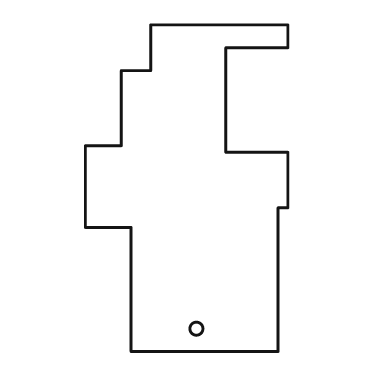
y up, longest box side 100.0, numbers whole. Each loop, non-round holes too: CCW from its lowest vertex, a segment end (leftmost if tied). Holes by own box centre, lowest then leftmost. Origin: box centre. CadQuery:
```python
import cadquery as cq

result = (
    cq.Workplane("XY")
    .moveTo(-17.0, -50.0)
    .lineTo(28.0, -50.0)
    .lineTo(28.0, -6.0)
    .lineTo(31.0, -6.0)
    .lineTo(31.0, 11.0)
    .lineTo(12.0, 11.0)
    .lineTo(12.0, 43.0)
    .lineTo(31.0, 43.0)
    .lineTo(31.0, 50.0)
    .lineTo(-11.0, 50.0)
    .lineTo(-11.0, 36.0)
    .lineTo(-20.0, 36.0)
    .lineTo(-20.0, 13.0)
    .lineTo(-31.0, 13.0)
    .lineTo(-31.0, -12.0)
    .lineTo(-17.0, -12.0)
    .close()
    .moveTo(3.0, -43.0)
    .circle(2.0)
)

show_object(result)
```